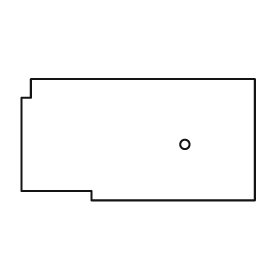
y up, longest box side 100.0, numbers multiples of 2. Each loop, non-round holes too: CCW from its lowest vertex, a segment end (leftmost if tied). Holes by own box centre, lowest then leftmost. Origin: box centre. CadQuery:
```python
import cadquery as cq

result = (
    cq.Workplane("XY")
    .moveTo(-20.0, -26.0)
    .lineTo(50.0, -26.0)
    .lineTo(50.0, 26.0)
    .lineTo(-46.0, 26.0)
    .lineTo(-46.0, 18.0)
    .lineTo(-50.0, 18.0)
    .lineTo(-50.0, -22.0)
    .lineTo(-20.0, -22.0)
    .close()
    .moveTo(20.0, -2.0)
    .circle(2.0)
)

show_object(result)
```